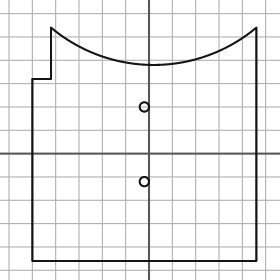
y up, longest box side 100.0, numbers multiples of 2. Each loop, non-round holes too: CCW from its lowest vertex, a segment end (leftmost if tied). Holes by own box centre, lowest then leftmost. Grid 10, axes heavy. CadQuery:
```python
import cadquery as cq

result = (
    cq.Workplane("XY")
    .moveTo(-50.0, -46.0)
    .lineTo(46.0, -46.0)
    .lineTo(46.0, 54.0)
    .threePointArc((2.0, 38.0), (-42.0, 54.0))
    .lineTo(-42.0, 32.0)
    .lineTo(-50.0, 32.0)
    .close()
    .moveTo(-2.0, -12.0)
    .circle(2.0)
    .moveTo(-2.0, 20.0)
    .circle(2.0)
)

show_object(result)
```